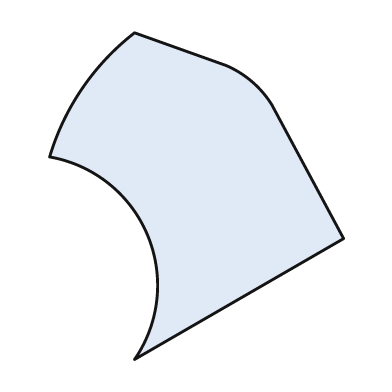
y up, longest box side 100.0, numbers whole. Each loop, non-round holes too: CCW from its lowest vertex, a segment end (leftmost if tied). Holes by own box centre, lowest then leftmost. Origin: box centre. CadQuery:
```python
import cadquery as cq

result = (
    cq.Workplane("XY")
    .moveTo(-19.0, -50.0)
    .lineTo(45.0, -13.0)
    .lineTo(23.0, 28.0)
    .threePointArc((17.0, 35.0), (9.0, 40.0))
    .lineTo(-19.0, 50.0)
    .threePointArc((-35.0, 33.0), (-45.0, 12.0))
    .threePointArc((-15.0, -12.0), (-19.0, -50.0))
    .close()
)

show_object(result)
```